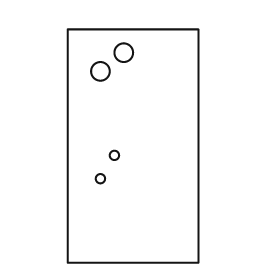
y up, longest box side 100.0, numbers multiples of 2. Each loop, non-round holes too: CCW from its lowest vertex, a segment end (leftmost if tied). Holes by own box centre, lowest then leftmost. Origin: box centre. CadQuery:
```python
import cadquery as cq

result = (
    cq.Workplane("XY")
    .moveTo(-28.0, -50.0)
    .lineTo(28.0, -50.0)
    .lineTo(28.0, 50.0)
    .lineTo(-28.0, 50.0)
    .close()
    .moveTo(-14.0, -14.0)
    .circle(2.0)
    .moveTo(-8.0, -4.0)
    .circle(2.0)
    .moveTo(-14.0, 32.0)
    .circle(4.0)
    .moveTo(-4.0, 40.0)
    .circle(4.0)
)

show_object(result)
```